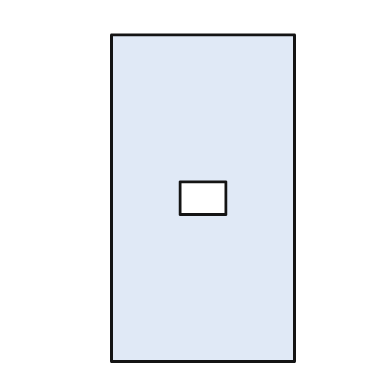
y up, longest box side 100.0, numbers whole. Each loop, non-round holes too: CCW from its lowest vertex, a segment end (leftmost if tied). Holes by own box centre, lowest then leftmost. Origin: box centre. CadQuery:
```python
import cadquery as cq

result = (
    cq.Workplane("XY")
    .moveTo(-28.0, -50.0)
    .lineTo(28.0, -50.0)
    .lineTo(28.0, 50.0)
    .lineTo(-28.0, 50.0)
    .close()
    .moveTo(-7.0, -5.0)
    .lineTo(7.0, -5.0)
    .lineTo(7.0, 5.0)
    .lineTo(-7.0, 5.0)
    .close()
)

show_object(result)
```